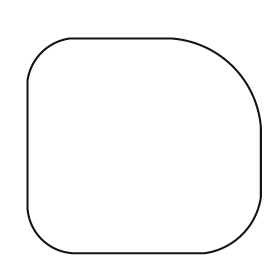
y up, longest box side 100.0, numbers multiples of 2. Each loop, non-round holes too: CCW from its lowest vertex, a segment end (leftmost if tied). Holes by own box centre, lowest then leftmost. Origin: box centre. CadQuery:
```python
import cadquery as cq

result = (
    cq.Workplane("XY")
    .moveTo(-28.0, -46.0)
    .lineTo(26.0, -46.0)
    .threePointArc((42.0, -38.0), (50.0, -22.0))
    .lineTo(50.0, 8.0)
    .threePointArc((38.0, 34.0), (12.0, 46.0))
    .lineTo(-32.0, 46.0)
    .threePointArc((-44.0, 40.0), (-50.0, 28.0))
    .lineTo(-50.0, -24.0)
    .threePointArc((-44.0, -40.0), (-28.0, -46.0))
    .close()
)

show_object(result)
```